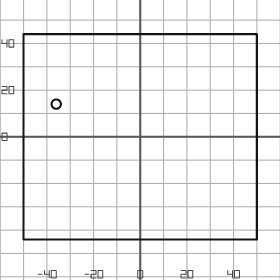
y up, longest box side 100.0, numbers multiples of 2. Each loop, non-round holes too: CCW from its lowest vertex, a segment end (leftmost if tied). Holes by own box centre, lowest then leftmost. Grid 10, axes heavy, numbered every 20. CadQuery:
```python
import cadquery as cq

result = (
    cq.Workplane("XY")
    .moveTo(-50.0, -44.0)
    .lineTo(50.0, -44.0)
    .lineTo(50.0, 44.0)
    .lineTo(-50.0, 44.0)
    .close()
    .moveTo(-36.0, 14.0)
    .circle(2.0)
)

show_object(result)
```